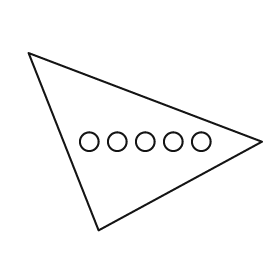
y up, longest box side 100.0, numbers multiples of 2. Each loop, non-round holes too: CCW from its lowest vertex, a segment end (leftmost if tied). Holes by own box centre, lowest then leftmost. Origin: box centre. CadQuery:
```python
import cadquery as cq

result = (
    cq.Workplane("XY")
    .moveTo(-20.0, -38.0)
    .lineTo(50.0, 0.0)
    .lineTo(-50.0, 38.0)
    .close()
    .moveTo(-24.0, 0.0)
    .circle(4.0)
    .moveTo(-12.0, 0.0)
    .circle(4.0)
    .moveTo(0.0, 0.0)
    .circle(4.0)
    .moveTo(12.0, 0.0)
    .circle(4.0)
    .moveTo(24.0, 0.0)
    .circle(4.0)
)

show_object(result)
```